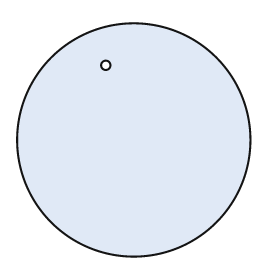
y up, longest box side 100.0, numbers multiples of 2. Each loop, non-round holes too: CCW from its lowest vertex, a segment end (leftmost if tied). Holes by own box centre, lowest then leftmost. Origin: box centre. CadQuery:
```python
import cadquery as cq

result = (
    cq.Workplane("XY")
    .moveTo(0.0, 0.0)
    .circle(50.0)
    .moveTo(-12.0, 32.0)
    .circle(2.0)
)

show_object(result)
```